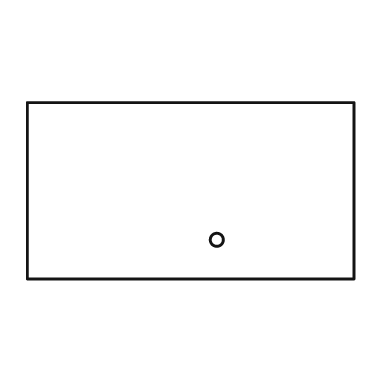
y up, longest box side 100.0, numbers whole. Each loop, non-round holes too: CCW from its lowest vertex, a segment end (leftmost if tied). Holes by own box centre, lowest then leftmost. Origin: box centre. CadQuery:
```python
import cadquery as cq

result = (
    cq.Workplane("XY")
    .moveTo(-50.0, -27.0)
    .lineTo(50.0, -27.0)
    .lineTo(50.0, 27.0)
    .lineTo(-50.0, 27.0)
    .close()
    .moveTo(8.0, -15.0)
    .circle(2.0)
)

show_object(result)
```